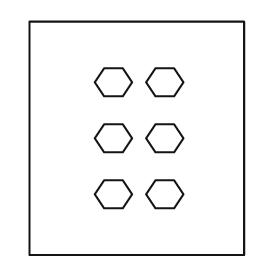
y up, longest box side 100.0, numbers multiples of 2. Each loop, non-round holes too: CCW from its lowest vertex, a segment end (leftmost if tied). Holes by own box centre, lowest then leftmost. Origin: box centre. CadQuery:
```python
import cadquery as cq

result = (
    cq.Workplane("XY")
    .moveTo(-46.0, -50.0)
    .lineTo(46.0, -50.0)
    .lineTo(46.0, 50.0)
    .lineTo(-46.0, 50.0)
    .close()
    .moveTo(-14.0, -30.0)
    .lineTo(-6.0, -30.0)
    .lineTo(-2.0, -24.0)
    .lineTo(-6.0, -18.0)
    .lineTo(-14.0, -18.0)
    .lineTo(-18.0, -24.0)
    .close()
    .moveTo(8.0, -30.0)
    .lineTo(16.0, -30.0)
    .lineTo(20.0, -24.0)
    .lineTo(16.0, -18.0)
    .lineTo(8.0, -18.0)
    .lineTo(4.0, -24.0)
    .close()
    .moveTo(-14.0, -6.0)
    .lineTo(-6.0, -6.0)
    .lineTo(-2.0, 0.0)
    .lineTo(-6.0, 6.0)
    .lineTo(-14.0, 6.0)
    .lineTo(-18.0, 0.0)
    .close()
    .moveTo(8.0, -6.0)
    .lineTo(16.0, -6.0)
    .lineTo(20.0, 0.0)
    .lineTo(16.0, 6.0)
    .lineTo(8.0, 6.0)
    .lineTo(4.0, 0.0)
    .close()
    .moveTo(-14.0, 18.0)
    .lineTo(-6.0, 18.0)
    .lineTo(-2.0, 24.0)
    .lineTo(-6.0, 30.0)
    .lineTo(-14.0, 30.0)
    .lineTo(-18.0, 24.0)
    .close()
    .moveTo(8.0, 18.0)
    .lineTo(16.0, 18.0)
    .lineTo(20.0, 24.0)
    .lineTo(16.0, 30.0)
    .lineTo(8.0, 30.0)
    .lineTo(4.0, 24.0)
    .close()
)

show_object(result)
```